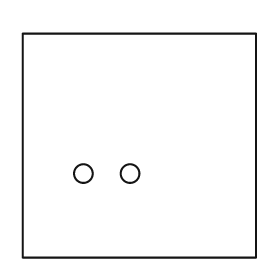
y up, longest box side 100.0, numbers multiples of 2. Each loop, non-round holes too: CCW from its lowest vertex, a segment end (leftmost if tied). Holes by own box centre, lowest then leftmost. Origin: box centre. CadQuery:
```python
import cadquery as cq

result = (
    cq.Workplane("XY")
    .moveTo(-50.0, -48.0)
    .lineTo(50.0, -48.0)
    .lineTo(50.0, 48.0)
    .lineTo(-50.0, 48.0)
    .close()
    .moveTo(-24.0, -12.0)
    .circle(4.0)
    .moveTo(-4.0, -12.0)
    .circle(4.0)
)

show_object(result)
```